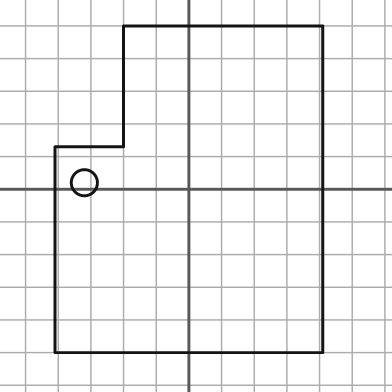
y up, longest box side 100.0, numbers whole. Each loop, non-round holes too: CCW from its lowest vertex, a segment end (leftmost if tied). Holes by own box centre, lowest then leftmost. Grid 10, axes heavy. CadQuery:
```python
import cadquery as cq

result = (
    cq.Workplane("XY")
    .moveTo(-41.0, -50.0)
    .lineTo(41.0, -50.0)
    .lineTo(41.0, 50.0)
    .lineTo(-20.0, 50.0)
    .lineTo(-20.0, 13.0)
    .lineTo(-41.0, 13.0)
    .close()
    .moveTo(-32.0, 2.0)
    .circle(4.0)
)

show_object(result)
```